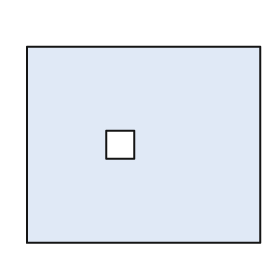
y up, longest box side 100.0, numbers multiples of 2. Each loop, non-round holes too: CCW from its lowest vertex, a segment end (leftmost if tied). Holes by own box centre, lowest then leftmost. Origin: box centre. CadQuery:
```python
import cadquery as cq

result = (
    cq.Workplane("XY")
    .moveTo(-50.0, -42.0)
    .lineTo(50.0, -42.0)
    .lineTo(50.0, 42.0)
    .lineTo(-50.0, 42.0)
    .close()
    .moveTo(-16.0, -6.0)
    .lineTo(-4.0, -6.0)
    .lineTo(-4.0, 6.0)
    .lineTo(-16.0, 6.0)
    .close()
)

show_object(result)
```